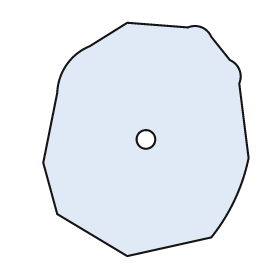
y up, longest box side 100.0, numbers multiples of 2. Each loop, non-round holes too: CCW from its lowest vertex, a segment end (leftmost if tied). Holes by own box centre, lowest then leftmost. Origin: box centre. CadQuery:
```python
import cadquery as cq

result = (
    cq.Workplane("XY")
    .moveTo(-8.0, -50.0)
    .lineTo(28.0, -42.0)
    .threePointArc((38.0, -26.0), (44.0, -8.0))
    .lineTo(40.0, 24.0)
    .threePointArc((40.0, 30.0), (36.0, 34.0))
    .lineTo(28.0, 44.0)
    .threePointArc((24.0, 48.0), (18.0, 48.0))
    .lineTo(-8.0, 50.0)
    .lineTo(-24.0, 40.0)
    .threePointArc((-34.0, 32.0), (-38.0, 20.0))
    .lineTo(-44.0, -10.0)
    .lineTo(-38.0, -32.0)
    .close()
    .moveTo(0.0, 0.0)
    .circle(4.0)
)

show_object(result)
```